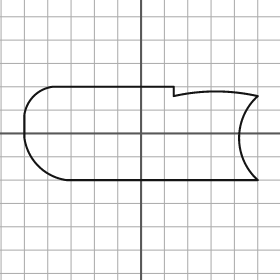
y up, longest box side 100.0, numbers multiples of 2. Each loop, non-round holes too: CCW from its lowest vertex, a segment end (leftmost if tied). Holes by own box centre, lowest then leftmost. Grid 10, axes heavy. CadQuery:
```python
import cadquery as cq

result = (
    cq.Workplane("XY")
    .moveTo(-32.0, -20.0)
    .lineTo(50.0, -20.0)
    .threePointArc((42.0, -2.0), (50.0, 16.0))
    .threePointArc((32.0, 18.0), (14.0, 16.0))
    .lineTo(14.0, 20.0)
    .lineTo(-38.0, 20.0)
    .threePointArc((-46.0, 16.0), (-50.0, 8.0))
    .lineTo(-50.0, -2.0)
    .threePointArc((-44.0, -14.0), (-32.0, -20.0))
    .close()
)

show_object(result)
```